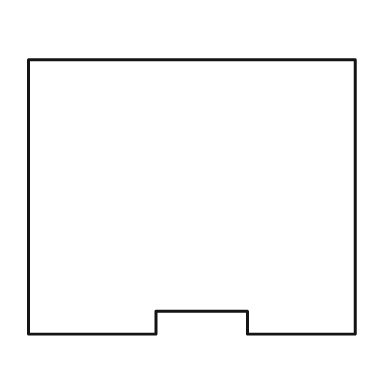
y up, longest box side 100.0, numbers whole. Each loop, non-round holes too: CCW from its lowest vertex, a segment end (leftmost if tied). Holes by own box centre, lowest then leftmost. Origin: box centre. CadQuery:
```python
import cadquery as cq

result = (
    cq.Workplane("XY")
    .moveTo(-50.0, -42.0)
    .lineTo(-11.0, -42.0)
    .lineTo(-11.0, -35.0)
    .lineTo(17.0, -35.0)
    .lineTo(17.0, -42.0)
    .lineTo(50.0, -42.0)
    .lineTo(50.0, 42.0)
    .lineTo(-50.0, 42.0)
    .close()
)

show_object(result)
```